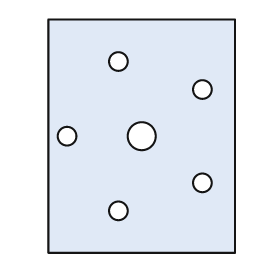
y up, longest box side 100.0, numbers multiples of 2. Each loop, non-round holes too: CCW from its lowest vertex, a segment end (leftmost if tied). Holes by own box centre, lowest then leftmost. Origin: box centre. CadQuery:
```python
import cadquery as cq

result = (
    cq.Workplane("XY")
    .moveTo(-40.0, -50.0)
    .lineTo(40.0, -50.0)
    .lineTo(40.0, 50.0)
    .lineTo(-40.0, 50.0)
    .close()
    .moveTo(-10.0, -32.0)
    .circle(4.0)
    .moveTo(26.0, -20.0)
    .circle(4.0)
    .moveTo(-32.0, 0.0)
    .circle(4.0)
    .moveTo(0.0, 0.0)
    .circle(6.0)
    .moveTo(26.0, 20.0)
    .circle(4.0)
    .moveTo(-10.0, 32.0)
    .circle(4.0)
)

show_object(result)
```